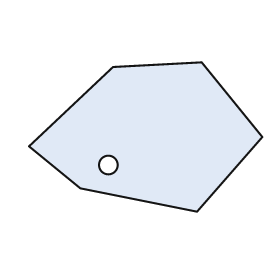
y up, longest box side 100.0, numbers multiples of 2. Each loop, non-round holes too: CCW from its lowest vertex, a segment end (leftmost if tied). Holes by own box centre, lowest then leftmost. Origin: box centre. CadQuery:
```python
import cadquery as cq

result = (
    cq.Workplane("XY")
    .moveTo(22.0, -32.0)
    .lineTo(50.0, 0.0)
    .lineTo(24.0, 32.0)
    .lineTo(-14.0, 30.0)
    .lineTo(-50.0, -4.0)
    .lineTo(-28.0, -22.0)
    .close()
    .moveTo(-16.0, -12.0)
    .circle(4.0)
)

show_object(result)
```